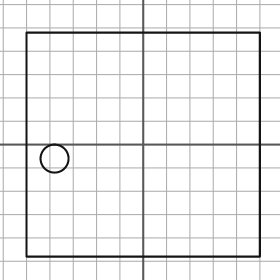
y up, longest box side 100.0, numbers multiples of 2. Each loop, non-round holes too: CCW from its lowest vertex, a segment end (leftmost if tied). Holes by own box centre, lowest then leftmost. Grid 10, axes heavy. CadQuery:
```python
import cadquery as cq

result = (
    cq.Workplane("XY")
    .moveTo(-50.0, -48.0)
    .lineTo(50.0, -48.0)
    .lineTo(50.0, 48.0)
    .lineTo(-50.0, 48.0)
    .close()
    .moveTo(-38.0, -6.0)
    .circle(6.0)
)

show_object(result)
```